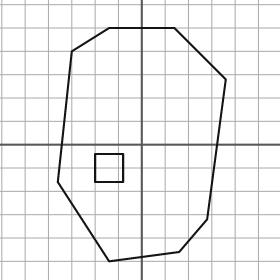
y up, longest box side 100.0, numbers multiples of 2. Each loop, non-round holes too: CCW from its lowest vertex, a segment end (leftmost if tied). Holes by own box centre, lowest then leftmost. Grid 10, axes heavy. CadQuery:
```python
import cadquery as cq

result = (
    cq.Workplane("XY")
    .moveTo(-14.0, -50.0)
    .lineTo(16.0, -46.0)
    .lineTo(28.0, -32.0)
    .lineTo(36.0, 28.0)
    .lineTo(14.0, 50.0)
    .lineTo(-14.0, 50.0)
    .lineTo(-30.0, 40.0)
    .lineTo(-36.0, -16.0)
    .close()
    .moveTo(-20.0, -16.0)
    .lineTo(-8.0, -16.0)
    .lineTo(-8.0, -4.0)
    .lineTo(-20.0, -4.0)
    .close()
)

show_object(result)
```